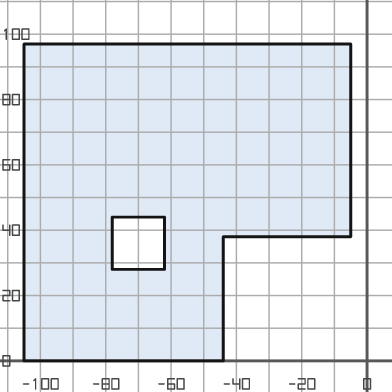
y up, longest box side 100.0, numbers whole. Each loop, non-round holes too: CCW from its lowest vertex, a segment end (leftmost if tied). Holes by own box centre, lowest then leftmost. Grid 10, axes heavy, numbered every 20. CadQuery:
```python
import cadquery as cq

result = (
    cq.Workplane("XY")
    .moveTo(-105.0, 0.0)
    .lineTo(-44.0, 0.0)
    .lineTo(-44.0, 38.0)
    .lineTo(-5.0, 38.0)
    .lineTo(-5.0, 97.0)
    .lineTo(-105.0, 97.0)
    .close()
    .moveTo(-78.0, 28.0)
    .lineTo(-62.0, 28.0)
    .lineTo(-62.0, 44.0)
    .lineTo(-78.0, 44.0)
    .close()
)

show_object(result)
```